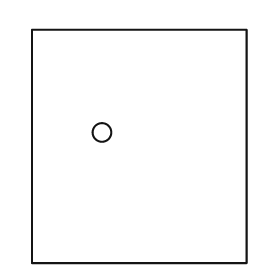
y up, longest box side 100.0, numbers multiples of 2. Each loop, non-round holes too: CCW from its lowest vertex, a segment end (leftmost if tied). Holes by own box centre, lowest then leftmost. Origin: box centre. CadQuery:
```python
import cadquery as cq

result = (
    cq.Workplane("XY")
    .moveTo(-46.0, -50.0)
    .lineTo(46.0, -50.0)
    .lineTo(46.0, 50.0)
    .lineTo(-46.0, 50.0)
    .close()
    .moveTo(-16.0, 6.0)
    .circle(4.0)
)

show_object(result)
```